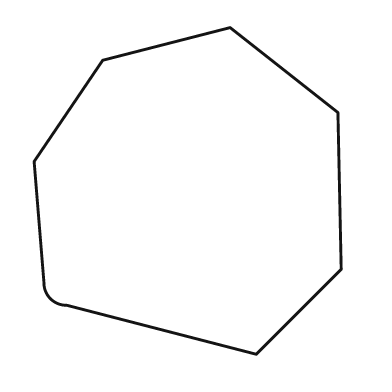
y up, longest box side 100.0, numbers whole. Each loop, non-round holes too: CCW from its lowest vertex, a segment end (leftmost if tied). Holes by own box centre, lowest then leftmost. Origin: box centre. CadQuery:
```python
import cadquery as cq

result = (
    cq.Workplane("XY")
    .moveTo(21.0, -50.0)
    .lineTo(47.0, -24.0)
    .lineTo(46.0, 24.0)
    .lineTo(13.0, 50.0)
    .lineTo(-26.0, 40.0)
    .lineTo(-47.0, 9.0)
    .lineTo(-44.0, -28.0)
    .threePointArc((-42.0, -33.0), (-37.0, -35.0))
    .close()
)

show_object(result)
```